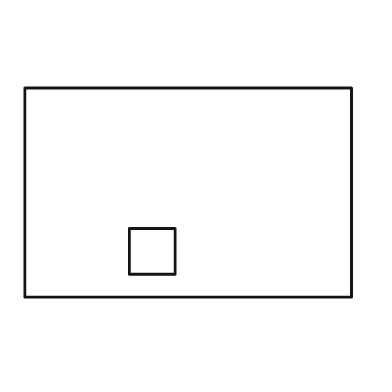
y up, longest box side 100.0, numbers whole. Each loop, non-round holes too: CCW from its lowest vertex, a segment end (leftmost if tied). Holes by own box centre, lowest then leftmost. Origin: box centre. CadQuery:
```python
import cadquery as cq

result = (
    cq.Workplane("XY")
    .moveTo(-50.0, -32.0)
    .lineTo(50.0, -32.0)
    .lineTo(50.0, 32.0)
    .lineTo(-50.0, 32.0)
    .close()
    .moveTo(-18.0, -25.0)
    .lineTo(-4.0, -25.0)
    .lineTo(-4.0, -11.0)
    .lineTo(-18.0, -11.0)
    .close()
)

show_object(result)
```